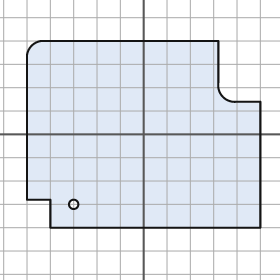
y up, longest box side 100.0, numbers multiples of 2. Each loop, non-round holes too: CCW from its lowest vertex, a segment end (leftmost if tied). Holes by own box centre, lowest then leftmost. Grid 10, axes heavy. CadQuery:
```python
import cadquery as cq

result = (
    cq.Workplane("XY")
    .moveTo(-40.0, -40.0)
    .lineTo(50.0, -40.0)
    .lineTo(50.0, 14.0)
    .lineTo(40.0, 14.0)
    .threePointArc((34.0, 16.0), (32.0, 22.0))
    .lineTo(32.0, 40.0)
    .lineTo(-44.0, 40.0)
    .threePointArc((-48.0, 38.0), (-50.0, 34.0))
    .lineTo(-50.0, -28.0)
    .lineTo(-40.0, -28.0)
    .close()
    .moveTo(-30.0, -30.0)
    .circle(2.0)
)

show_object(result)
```